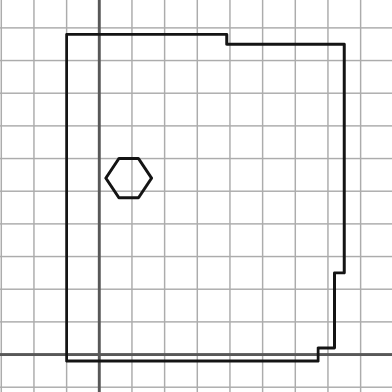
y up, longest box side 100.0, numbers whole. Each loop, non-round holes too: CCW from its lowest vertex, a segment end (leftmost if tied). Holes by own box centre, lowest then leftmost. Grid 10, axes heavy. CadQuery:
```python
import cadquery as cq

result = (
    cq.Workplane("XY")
    .moveTo(-10.0, -2.0)
    .lineTo(67.0, -2.0)
    .lineTo(67.0, 2.0)
    .lineTo(72.0, 2.0)
    .lineTo(72.0, 25.0)
    .lineTo(75.0, 25.0)
    .lineTo(75.0, 95.0)
    .lineTo(39.0, 95.0)
    .lineTo(39.0, 98.0)
    .lineTo(-10.0, 98.0)
    .close()
    .moveTo(6.0, 48.0)
    .lineTo(12.0, 48.0)
    .lineTo(16.0, 54.0)
    .lineTo(12.0, 60.0)
    .lineTo(6.0, 60.0)
    .lineTo(2.0, 54.0)
    .close()
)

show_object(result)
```